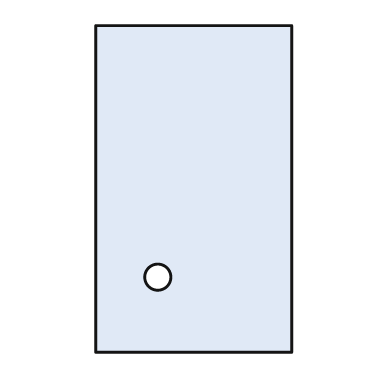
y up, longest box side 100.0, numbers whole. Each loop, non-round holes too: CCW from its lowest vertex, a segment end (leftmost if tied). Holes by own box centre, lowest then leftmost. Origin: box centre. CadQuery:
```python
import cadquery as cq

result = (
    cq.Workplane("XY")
    .moveTo(-30.0, -50.0)
    .lineTo(30.0, -50.0)
    .lineTo(30.0, 50.0)
    .lineTo(-30.0, 50.0)
    .close()
    .moveTo(-11.0, -27.0)
    .circle(4.0)
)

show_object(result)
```